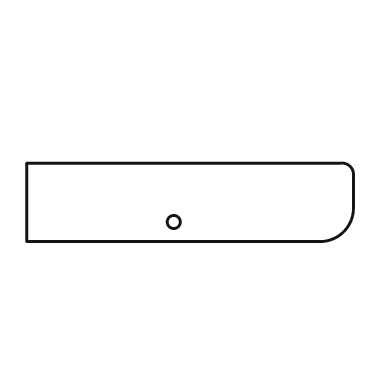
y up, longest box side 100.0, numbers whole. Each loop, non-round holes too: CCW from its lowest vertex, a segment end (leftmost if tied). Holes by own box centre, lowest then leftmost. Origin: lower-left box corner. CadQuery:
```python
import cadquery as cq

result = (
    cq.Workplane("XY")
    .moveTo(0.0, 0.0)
    .lineTo(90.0, 0.0)
    .threePointArc((97.0, 3.0), (100.0, 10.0))
    .lineTo(100.0, 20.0)
    .threePointArc((99.0, 23.0), (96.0, 24.0))
    .lineTo(0.0, 24.0)
    .close()
    .moveTo(45.0, 6.0)
    .circle(2.0)
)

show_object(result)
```